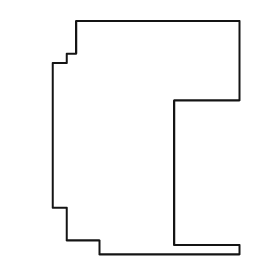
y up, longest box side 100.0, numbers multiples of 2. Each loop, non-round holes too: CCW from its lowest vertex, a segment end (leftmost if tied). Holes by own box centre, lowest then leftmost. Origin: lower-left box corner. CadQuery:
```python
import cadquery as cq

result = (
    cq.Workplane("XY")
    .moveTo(20.0, 0.0)
    .lineTo(80.0, 0.0)
    .lineTo(80.0, 4.0)
    .lineTo(52.0, 4.0)
    .lineTo(52.0, 66.0)
    .lineTo(80.0, 66.0)
    .lineTo(80.0, 100.0)
    .lineTo(10.0, 100.0)
    .lineTo(10.0, 86.0)
    .lineTo(6.0, 86.0)
    .lineTo(6.0, 82.0)
    .lineTo(0.0, 82.0)
    .lineTo(0.0, 20.0)
    .lineTo(6.0, 20.0)
    .lineTo(6.0, 6.0)
    .lineTo(20.0, 6.0)
    .close()
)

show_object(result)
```